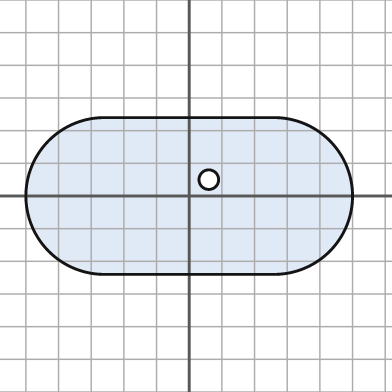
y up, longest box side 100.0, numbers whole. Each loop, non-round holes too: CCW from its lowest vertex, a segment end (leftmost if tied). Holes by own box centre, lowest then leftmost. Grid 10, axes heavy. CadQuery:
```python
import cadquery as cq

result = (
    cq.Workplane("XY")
    .moveTo(-26.0, -24.0)
    .lineTo(26.0, -24.0)
    .threePointArc((50.0, 0.0), (26.0, 24.0))
    .lineTo(-26.0, 24.0)
    .threePointArc((-50.0, 0.0), (-26.0, -24.0))
    .close()
    .moveTo(6.0, 5.0)
    .circle(3.0)
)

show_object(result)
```